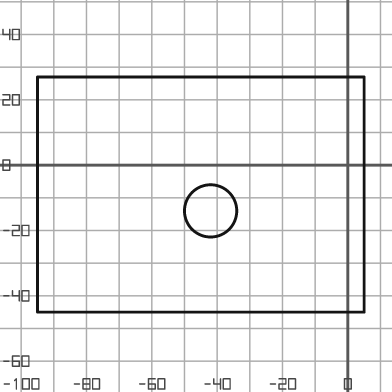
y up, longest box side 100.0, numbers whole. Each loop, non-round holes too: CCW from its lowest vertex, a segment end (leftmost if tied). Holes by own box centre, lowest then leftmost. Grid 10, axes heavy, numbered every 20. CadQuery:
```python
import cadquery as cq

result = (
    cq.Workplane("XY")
    .moveTo(-95.0, -45.0)
    .lineTo(5.0, -45.0)
    .lineTo(5.0, 27.0)
    .lineTo(-95.0, 27.0)
    .close()
    .moveTo(-42.0, -14.0)
    .circle(8.0)
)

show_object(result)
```